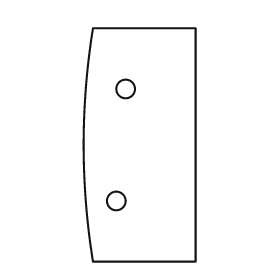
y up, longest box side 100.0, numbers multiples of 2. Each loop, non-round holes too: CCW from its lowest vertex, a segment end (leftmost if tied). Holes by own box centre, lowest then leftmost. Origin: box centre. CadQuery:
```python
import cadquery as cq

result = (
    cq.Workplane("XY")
    .moveTo(-20.0, -50.0)
    .lineTo(24.0, -50.0)
    .lineTo(24.0, 50.0)
    .lineTo(-20.0, 50.0)
    .threePointArc((-24.0, 0.0), (-20.0, -50.0))
    .close()
    .moveTo(-10.0, -24.0)
    .circle(4.0)
    .moveTo(-6.0, 24.0)
    .circle(4.0)
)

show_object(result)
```